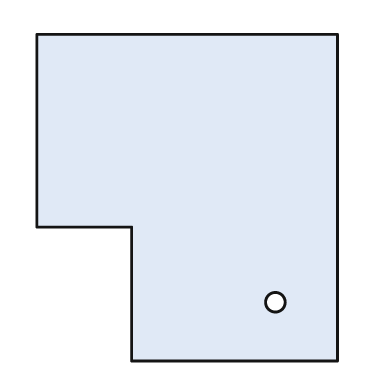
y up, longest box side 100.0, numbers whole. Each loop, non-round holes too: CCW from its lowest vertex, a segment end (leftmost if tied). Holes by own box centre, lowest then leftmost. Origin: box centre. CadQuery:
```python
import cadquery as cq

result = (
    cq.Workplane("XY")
    .moveTo(-17.0, -50.0)
    .lineTo(46.0, -50.0)
    .lineTo(46.0, 50.0)
    .lineTo(-46.0, 50.0)
    .lineTo(-46.0, -9.0)
    .lineTo(-17.0, -9.0)
    .close()
    .moveTo(27.0, -32.0)
    .circle(3.0)
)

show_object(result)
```